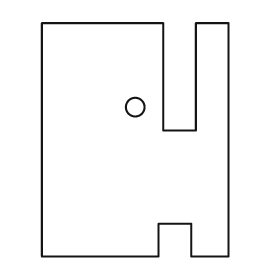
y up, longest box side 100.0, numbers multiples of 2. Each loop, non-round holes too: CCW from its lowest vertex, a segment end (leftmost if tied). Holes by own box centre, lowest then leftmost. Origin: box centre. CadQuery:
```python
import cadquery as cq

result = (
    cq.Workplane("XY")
    .moveTo(-40.0, -50.0)
    .lineTo(10.0, -50.0)
    .lineTo(10.0, -36.0)
    .lineTo(24.0, -36.0)
    .lineTo(24.0, -50.0)
    .lineTo(40.0, -50.0)
    .lineTo(40.0, 50.0)
    .lineTo(26.0, 50.0)
    .lineTo(26.0, 4.0)
    .lineTo(12.0, 4.0)
    .lineTo(12.0, 50.0)
    .lineTo(-40.0, 50.0)
    .close()
    .moveTo(0.0, 14.0)
    .circle(4.0)
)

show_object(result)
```